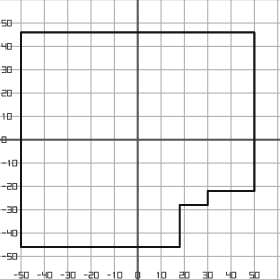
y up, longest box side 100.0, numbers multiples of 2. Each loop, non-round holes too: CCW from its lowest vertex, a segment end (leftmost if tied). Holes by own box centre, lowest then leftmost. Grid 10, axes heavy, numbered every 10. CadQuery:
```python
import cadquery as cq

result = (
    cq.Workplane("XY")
    .moveTo(-50.0, -46.0)
    .lineTo(18.0, -46.0)
    .lineTo(18.0, -28.0)
    .lineTo(30.0, -28.0)
    .lineTo(30.0, -22.0)
    .lineTo(50.0, -22.0)
    .lineTo(50.0, 46.0)
    .lineTo(-50.0, 46.0)
    .close()
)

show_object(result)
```